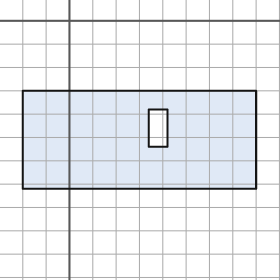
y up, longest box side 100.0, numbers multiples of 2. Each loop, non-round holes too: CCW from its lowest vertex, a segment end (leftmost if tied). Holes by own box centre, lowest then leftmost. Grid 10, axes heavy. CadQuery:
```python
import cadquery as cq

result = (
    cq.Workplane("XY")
    .moveTo(-20.0, -72.0)
    .lineTo(80.0, -72.0)
    .lineTo(80.0, -30.0)
    .lineTo(-20.0, -30.0)
    .close()
    .moveTo(34.0, -54.0)
    .lineTo(42.0, -54.0)
    .lineTo(42.0, -38.0)
    .lineTo(34.0, -38.0)
    .close()
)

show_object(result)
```